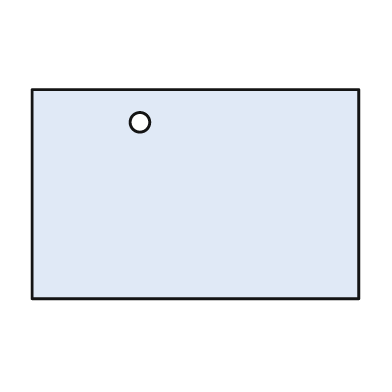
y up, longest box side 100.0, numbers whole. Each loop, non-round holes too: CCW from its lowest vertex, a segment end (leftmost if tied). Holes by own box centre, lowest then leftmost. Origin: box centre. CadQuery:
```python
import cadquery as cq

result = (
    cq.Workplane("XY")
    .moveTo(-50.0, -32.0)
    .lineTo(50.0, -32.0)
    .lineTo(50.0, 32.0)
    .lineTo(-50.0, 32.0)
    .close()
    .moveTo(-17.0, 22.0)
    .circle(3.0)
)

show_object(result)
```